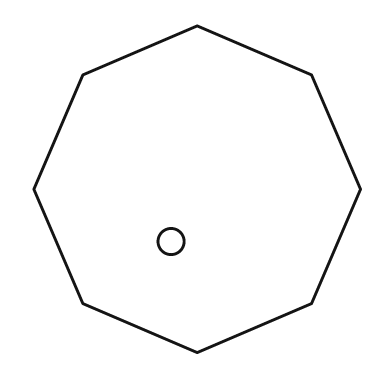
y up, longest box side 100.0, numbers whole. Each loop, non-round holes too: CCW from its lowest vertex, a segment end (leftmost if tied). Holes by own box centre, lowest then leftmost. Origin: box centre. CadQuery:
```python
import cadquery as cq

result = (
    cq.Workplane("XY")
    .moveTo(0.0, -50.0)
    .lineTo(35.0, -35.0)
    .lineTo(50.0, 0.0)
    .lineTo(35.0, 35.0)
    .lineTo(0.0, 50.0)
    .lineTo(-35.0, 35.0)
    .lineTo(-50.0, 0.0)
    .lineTo(-35.0, -35.0)
    .close()
    .moveTo(-8.0, -16.0)
    .circle(4.0)
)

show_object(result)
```